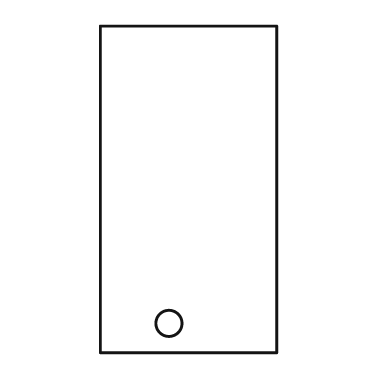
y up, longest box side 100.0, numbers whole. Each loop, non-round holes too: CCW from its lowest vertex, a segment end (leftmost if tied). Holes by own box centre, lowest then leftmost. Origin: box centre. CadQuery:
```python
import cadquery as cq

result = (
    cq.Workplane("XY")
    .moveTo(-27.0, -50.0)
    .lineTo(27.0, -50.0)
    .lineTo(27.0, 50.0)
    .lineTo(-27.0, 50.0)
    .close()
    .moveTo(-6.0, -41.0)
    .circle(4.0)
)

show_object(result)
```